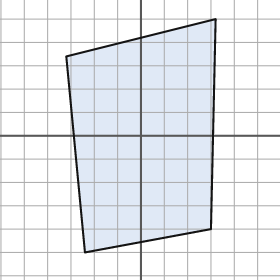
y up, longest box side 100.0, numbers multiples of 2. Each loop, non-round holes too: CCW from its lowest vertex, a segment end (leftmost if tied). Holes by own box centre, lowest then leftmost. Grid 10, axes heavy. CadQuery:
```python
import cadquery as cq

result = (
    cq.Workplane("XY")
    .moveTo(-24.0, -50.0)
    .lineTo(30.0, -40.0)
    .lineTo(32.0, 50.0)
    .lineTo(-32.0, 34.0)
    .close()
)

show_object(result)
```